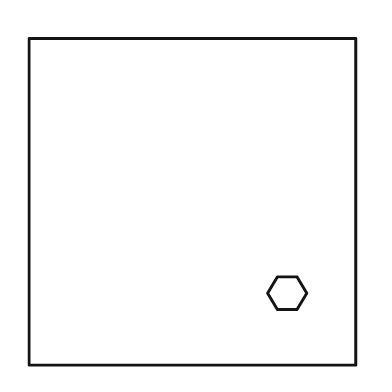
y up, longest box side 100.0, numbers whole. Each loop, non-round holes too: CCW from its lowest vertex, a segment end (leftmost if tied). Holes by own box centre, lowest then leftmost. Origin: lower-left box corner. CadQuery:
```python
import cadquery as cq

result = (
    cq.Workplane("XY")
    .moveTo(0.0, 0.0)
    .lineTo(100.0, 0.0)
    .lineTo(100.0, 100.0)
    .lineTo(0.0, 100.0)
    .close()
    .moveTo(76.0, 17.0)
    .lineTo(82.0, 17.0)
    .lineTo(85.0, 22.0)
    .lineTo(82.0, 27.0)
    .lineTo(76.0, 27.0)
    .lineTo(73.0, 22.0)
    .close()
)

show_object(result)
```